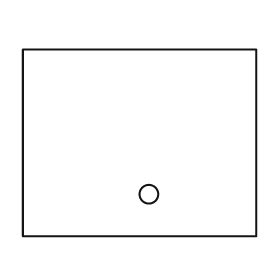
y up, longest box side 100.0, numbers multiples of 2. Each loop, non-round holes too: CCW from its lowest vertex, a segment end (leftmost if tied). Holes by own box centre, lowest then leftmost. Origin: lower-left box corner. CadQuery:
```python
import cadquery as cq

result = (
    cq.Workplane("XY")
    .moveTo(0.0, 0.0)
    .lineTo(100.0, 0.0)
    .lineTo(100.0, 80.0)
    .lineTo(0.0, 80.0)
    .close()
    .moveTo(54.0, 18.0)
    .circle(4.0)
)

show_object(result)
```